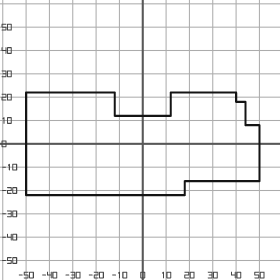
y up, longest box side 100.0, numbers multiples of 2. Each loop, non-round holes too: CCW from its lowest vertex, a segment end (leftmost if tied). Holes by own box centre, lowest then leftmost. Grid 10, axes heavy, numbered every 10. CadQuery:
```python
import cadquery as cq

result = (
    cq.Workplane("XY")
    .moveTo(-50.0, -22.0)
    .lineTo(18.0, -22.0)
    .lineTo(18.0, -16.0)
    .lineTo(50.0, -16.0)
    .lineTo(50.0, 8.0)
    .lineTo(44.0, 8.0)
    .lineTo(44.0, 18.0)
    .lineTo(40.0, 18.0)
    .lineTo(40.0, 22.0)
    .lineTo(12.0, 22.0)
    .lineTo(12.0, 12.0)
    .lineTo(-12.0, 12.0)
    .lineTo(-12.0, 22.0)
    .lineTo(-50.0, 22.0)
    .close()
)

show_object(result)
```